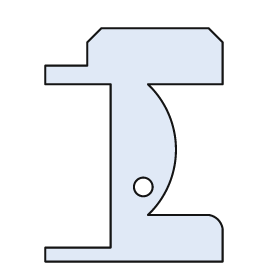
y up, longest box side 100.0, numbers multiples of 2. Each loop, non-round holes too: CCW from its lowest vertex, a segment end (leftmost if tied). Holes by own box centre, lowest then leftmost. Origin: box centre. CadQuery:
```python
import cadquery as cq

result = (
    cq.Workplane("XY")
    .moveTo(-38.0, -50.0)
    .lineTo(38.0, -50.0)
    .lineTo(38.0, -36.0)
    .threePointArc((36.0, -32.0), (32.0, -30.0))
    .lineTo(6.0, -30.0)
    .threePointArc((18.0, -2.0), (6.0, 26.0))
    .lineTo(38.0, 26.0)
    .lineTo(38.0, 44.0)
    .lineTo(32.0, 50.0)
    .lineTo(-14.0, 50.0)
    .lineTo(-20.0, 44.0)
    .lineTo(-20.0, 34.0)
    .lineTo(-38.0, 34.0)
    .lineTo(-38.0, 26.0)
    .lineTo(-10.0, 26.0)
    .lineTo(-10.0, -44.0)
    .lineTo(-38.0, -44.0)
    .close()
    .moveTo(4.0, -18.0)
    .circle(4.0)
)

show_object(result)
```